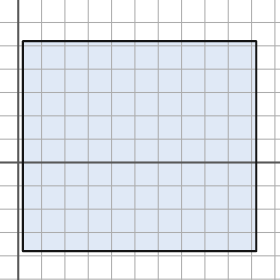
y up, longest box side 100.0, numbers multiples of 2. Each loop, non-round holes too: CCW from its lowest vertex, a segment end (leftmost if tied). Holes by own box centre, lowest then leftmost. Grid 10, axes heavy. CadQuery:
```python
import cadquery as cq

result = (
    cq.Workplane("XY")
    .moveTo(2.0, -38.0)
    .lineTo(102.0, -38.0)
    .lineTo(102.0, 52.0)
    .lineTo(2.0, 52.0)
    .close()
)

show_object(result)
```